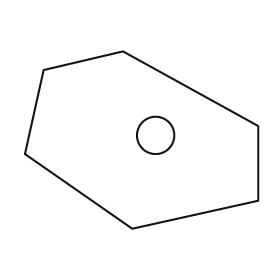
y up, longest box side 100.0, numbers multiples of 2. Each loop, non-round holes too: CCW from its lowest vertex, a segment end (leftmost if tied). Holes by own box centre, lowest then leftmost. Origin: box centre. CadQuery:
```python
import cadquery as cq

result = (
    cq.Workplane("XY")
    .moveTo(-4.0, -38.0)
    .lineTo(50.0, -26.0)
    .lineTo(50.0, 6.0)
    .lineTo(-8.0, 38.0)
    .lineTo(-42.0, 30.0)
    .lineTo(-50.0, -6.0)
    .close()
    .moveTo(6.0, 2.0)
    .circle(8.0)
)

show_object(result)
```